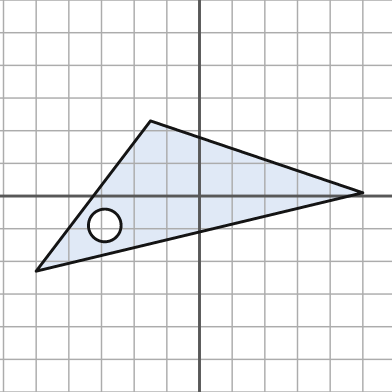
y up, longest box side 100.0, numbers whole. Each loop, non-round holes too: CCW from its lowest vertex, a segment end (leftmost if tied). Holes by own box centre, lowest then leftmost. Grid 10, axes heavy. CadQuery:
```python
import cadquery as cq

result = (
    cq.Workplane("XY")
    .moveTo(-50.0, -23.0)
    .lineTo(50.0, 1.0)
    .lineTo(-15.0, 23.0)
    .close()
    .moveTo(-29.0, -9.0)
    .circle(5.0)
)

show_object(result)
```